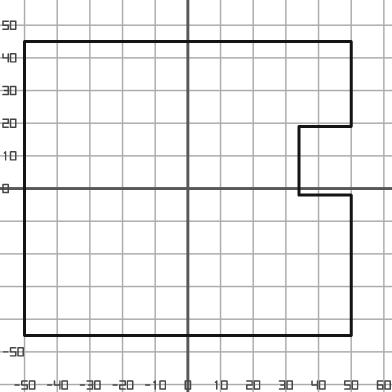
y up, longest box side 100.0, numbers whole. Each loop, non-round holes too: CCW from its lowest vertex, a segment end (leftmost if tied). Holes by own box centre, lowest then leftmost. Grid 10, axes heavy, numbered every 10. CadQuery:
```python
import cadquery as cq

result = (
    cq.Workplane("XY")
    .moveTo(-50.0, -45.0)
    .lineTo(50.0, -45.0)
    .lineTo(50.0, -2.0)
    .lineTo(34.0, -2.0)
    .lineTo(34.0, 19.0)
    .lineTo(50.0, 19.0)
    .lineTo(50.0, 45.0)
    .lineTo(-50.0, 45.0)
    .close()
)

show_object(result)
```